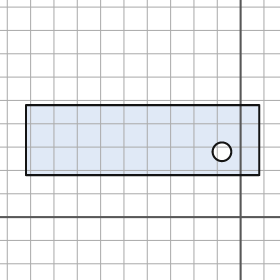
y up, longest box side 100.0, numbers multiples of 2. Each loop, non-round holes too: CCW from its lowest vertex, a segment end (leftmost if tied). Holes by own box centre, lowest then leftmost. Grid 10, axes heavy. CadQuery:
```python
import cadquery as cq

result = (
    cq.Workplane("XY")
    .moveTo(-92.0, 18.0)
    .lineTo(8.0, 18.0)
    .lineTo(8.0, 48.0)
    .lineTo(-92.0, 48.0)
    .close()
    .moveTo(-8.0, 28.0)
    .circle(4.0)
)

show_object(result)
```